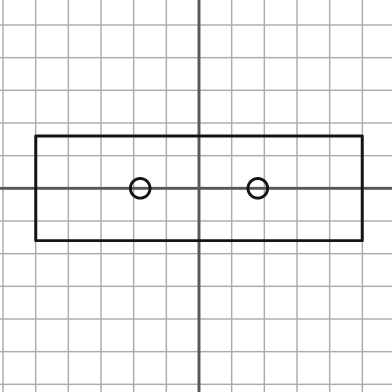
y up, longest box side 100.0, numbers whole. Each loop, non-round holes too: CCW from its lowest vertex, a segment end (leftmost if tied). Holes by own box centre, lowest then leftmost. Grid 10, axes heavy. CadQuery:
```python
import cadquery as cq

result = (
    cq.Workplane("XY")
    .moveTo(-50.0, -16.0)
    .lineTo(50.0, -16.0)
    .lineTo(50.0, 16.0)
    .lineTo(-50.0, 16.0)
    .close()
    .moveTo(-18.0, 0.0)
    .circle(3.0)
    .moveTo(18.0, 0.0)
    .circle(3.0)
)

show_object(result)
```